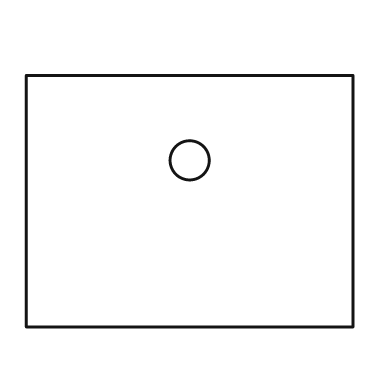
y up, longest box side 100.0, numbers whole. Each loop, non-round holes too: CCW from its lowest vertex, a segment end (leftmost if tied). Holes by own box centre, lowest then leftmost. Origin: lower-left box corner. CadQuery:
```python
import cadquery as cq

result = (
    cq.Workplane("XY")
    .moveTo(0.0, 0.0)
    .lineTo(100.0, 0.0)
    .lineTo(100.0, 77.0)
    .lineTo(0.0, 77.0)
    .close()
    .moveTo(50.0, 51.0)
    .circle(6.0)
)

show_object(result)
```